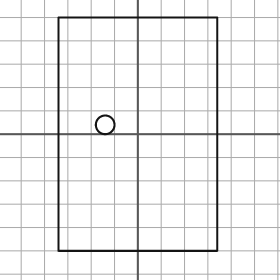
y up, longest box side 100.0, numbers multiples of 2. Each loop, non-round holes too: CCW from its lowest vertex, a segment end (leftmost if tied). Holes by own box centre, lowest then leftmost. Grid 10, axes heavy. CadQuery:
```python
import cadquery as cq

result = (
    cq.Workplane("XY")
    .moveTo(-34.0, -50.0)
    .lineTo(34.0, -50.0)
    .lineTo(34.0, 50.0)
    .lineTo(-34.0, 50.0)
    .close()
    .moveTo(-14.0, 4.0)
    .circle(4.0)
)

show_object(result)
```